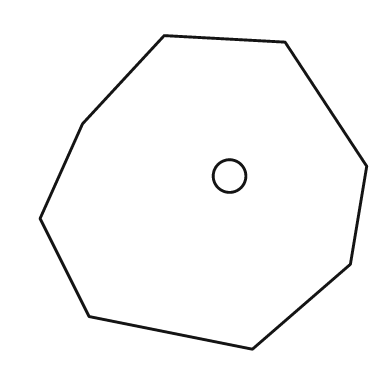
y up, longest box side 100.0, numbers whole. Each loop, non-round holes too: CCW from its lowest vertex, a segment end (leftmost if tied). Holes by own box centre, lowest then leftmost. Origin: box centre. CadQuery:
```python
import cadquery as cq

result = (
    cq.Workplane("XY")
    .moveTo(15.0, -48.0)
    .lineTo(45.0, -22.0)
    .lineTo(50.0, 8.0)
    .lineTo(25.0, 46.0)
    .lineTo(-12.0, 48.0)
    .lineTo(-37.0, 21.0)
    .lineTo(-50.0, -8.0)
    .lineTo(-35.0, -38.0)
    .close()
    .moveTo(8.0, 5.0)
    .circle(5.0)
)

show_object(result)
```